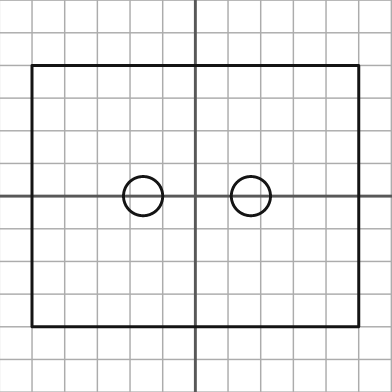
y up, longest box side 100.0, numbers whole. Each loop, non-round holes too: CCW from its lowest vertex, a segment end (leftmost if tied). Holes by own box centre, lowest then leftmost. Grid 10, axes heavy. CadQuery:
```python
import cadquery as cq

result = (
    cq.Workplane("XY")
    .moveTo(-50.0, -40.0)
    .lineTo(50.0, -40.0)
    .lineTo(50.0, 40.0)
    .lineTo(-50.0, 40.0)
    .close()
    .moveTo(-16.0, 0.0)
    .circle(6.0)
    .moveTo(17.0, 0.0)
    .circle(6.0)
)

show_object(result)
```